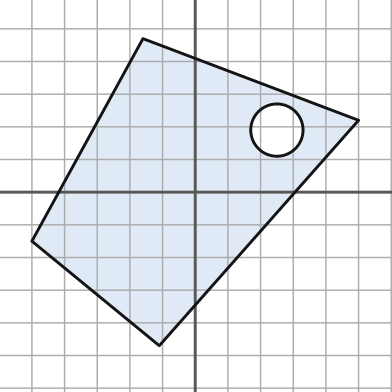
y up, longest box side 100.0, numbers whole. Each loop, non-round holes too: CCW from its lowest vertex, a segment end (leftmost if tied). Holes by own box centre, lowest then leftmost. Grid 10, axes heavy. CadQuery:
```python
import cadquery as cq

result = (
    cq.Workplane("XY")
    .moveTo(-11.0, -47.0)
    .lineTo(50.0, 22.0)
    .lineTo(-16.0, 47.0)
    .lineTo(-50.0, -15.0)
    .close()
    .moveTo(25.0, 19.0)
    .circle(8.0)
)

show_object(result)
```